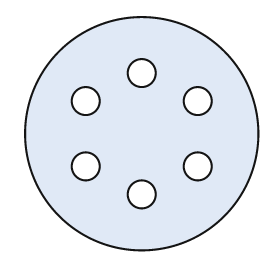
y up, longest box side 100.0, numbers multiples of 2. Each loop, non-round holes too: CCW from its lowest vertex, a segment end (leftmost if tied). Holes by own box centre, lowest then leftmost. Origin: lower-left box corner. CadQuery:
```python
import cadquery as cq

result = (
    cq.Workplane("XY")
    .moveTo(50.0, 50.0)
    .circle(50.0)
    .moveTo(50.0, 24.0)
    .circle(6.0)
    .moveTo(26.0, 36.0)
    .circle(6.0)
    .moveTo(74.0, 36.0)
    .circle(6.0)
    .moveTo(26.0, 64.0)
    .circle(6.0)
    .moveTo(74.0, 64.0)
    .circle(6.0)
    .moveTo(50.0, 76.0)
    .circle(6.0)
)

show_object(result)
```